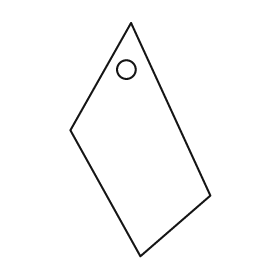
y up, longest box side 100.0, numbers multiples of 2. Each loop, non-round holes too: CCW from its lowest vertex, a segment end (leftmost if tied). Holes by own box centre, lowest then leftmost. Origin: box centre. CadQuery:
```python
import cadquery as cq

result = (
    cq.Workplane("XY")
    .moveTo(0.0, -50.0)
    .lineTo(30.0, -24.0)
    .lineTo(-4.0, 50.0)
    .lineTo(-30.0, 4.0)
    .close()
    .moveTo(-6.0, 30.0)
    .circle(4.0)
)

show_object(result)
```